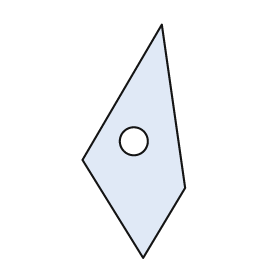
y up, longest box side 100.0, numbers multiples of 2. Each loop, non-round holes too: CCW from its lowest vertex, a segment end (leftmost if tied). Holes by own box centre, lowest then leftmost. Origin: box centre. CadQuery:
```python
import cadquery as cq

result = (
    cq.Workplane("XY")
    .moveTo(4.0, -50.0)
    .lineTo(22.0, -20.0)
    .lineTo(12.0, 50.0)
    .lineTo(-22.0, -8.0)
    .close()
    .moveTo(0.0, 0.0)
    .circle(6.0)
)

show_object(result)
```